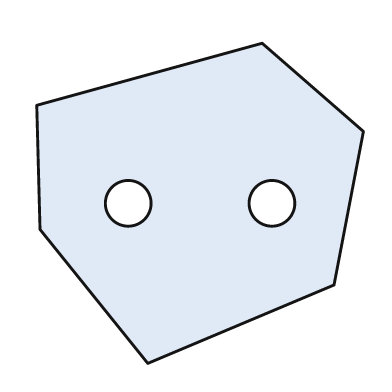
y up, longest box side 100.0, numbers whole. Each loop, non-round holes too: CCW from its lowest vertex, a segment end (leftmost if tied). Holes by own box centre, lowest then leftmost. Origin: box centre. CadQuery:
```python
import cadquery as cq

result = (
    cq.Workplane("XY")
    .moveTo(-16.0, -49.0)
    .lineTo(41.0, -25.0)
    .lineTo(50.0, 22.0)
    .lineTo(19.0, 49.0)
    .lineTo(-50.0, 30.0)
    .lineTo(-49.0, -8.0)
    .close()
    .moveTo(-22.0, 0.0)
    .circle(7.0)
    .moveTo(22.0, 0.0)
    .circle(7.0)
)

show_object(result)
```